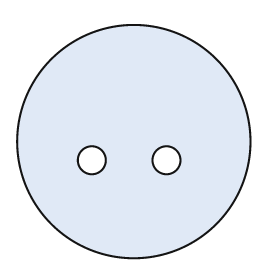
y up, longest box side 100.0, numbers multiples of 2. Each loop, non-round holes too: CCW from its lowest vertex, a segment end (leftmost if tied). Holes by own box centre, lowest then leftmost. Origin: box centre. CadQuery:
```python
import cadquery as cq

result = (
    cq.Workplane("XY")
    .moveTo(0.0, 0.0)
    .circle(50.0)
    .moveTo(-18.0, -8.0)
    .circle(6.0)
    .moveTo(14.0, -8.0)
    .circle(6.0)
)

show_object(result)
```